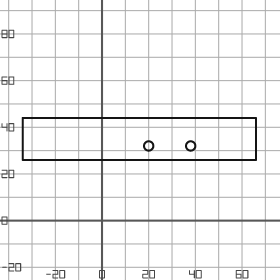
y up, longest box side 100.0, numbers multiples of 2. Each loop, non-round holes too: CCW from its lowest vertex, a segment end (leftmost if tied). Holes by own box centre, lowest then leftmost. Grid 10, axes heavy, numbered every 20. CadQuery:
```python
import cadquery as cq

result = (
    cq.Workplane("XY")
    .moveTo(-34.0, 26.0)
    .lineTo(66.0, 26.0)
    .lineTo(66.0, 44.0)
    .lineTo(-34.0, 44.0)
    .close()
    .moveTo(20.0, 32.0)
    .circle(2.0)
    .moveTo(38.0, 32.0)
    .circle(2.0)
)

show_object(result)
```